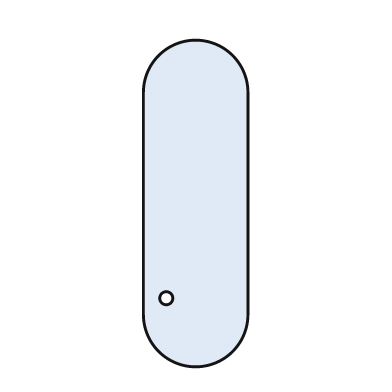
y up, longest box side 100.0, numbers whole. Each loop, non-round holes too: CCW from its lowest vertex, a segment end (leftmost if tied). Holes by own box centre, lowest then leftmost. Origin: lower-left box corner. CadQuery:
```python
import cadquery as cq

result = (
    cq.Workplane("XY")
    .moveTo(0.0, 16.0)
    .threePointArc((16.0, 0.0), (32.0, 16.0))
    .lineTo(32.0, 84.0)
    .threePointArc((16.0, 100.0), (0.0, 84.0))
    .close()
    .moveTo(7.0, 21.0)
    .circle(2.0)
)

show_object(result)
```